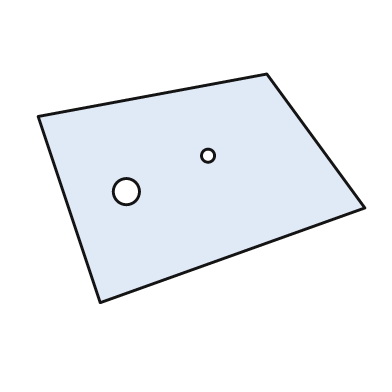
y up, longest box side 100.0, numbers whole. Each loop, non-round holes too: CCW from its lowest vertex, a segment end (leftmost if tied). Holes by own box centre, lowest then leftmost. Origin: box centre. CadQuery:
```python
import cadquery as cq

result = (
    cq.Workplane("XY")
    .moveTo(-31.0, -35.0)
    .lineTo(50.0, -6.0)
    .lineTo(20.0, 35.0)
    .lineTo(-50.0, 22.0)
    .close()
    .moveTo(-23.0, -1.0)
    .circle(4.0)
    .moveTo(2.0, 10.0)
    .circle(2.0)
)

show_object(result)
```